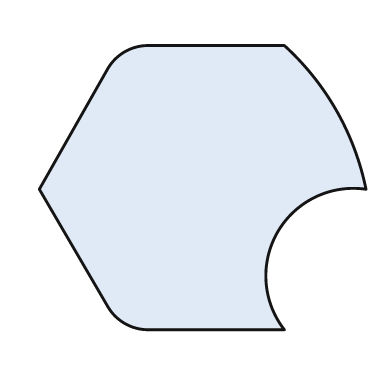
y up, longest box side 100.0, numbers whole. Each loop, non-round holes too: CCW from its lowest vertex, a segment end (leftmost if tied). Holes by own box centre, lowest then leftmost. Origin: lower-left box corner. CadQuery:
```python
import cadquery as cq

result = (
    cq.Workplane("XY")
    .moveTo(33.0, 0.0)
    .lineTo(75.0, 0.0)
    .threePointArc((73.0, 30.0), (100.0, 43.0))
    .threePointArc((91.0, 67.0), (75.0, 87.0))
    .lineTo(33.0, 87.0)
    .threePointArc((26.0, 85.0), (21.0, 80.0))
    .lineTo(0.0, 43.0)
    .lineTo(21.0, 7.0)
    .threePointArc((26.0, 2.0), (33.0, 0.0))
    .close()
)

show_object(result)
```